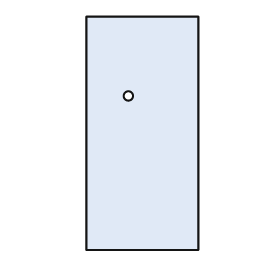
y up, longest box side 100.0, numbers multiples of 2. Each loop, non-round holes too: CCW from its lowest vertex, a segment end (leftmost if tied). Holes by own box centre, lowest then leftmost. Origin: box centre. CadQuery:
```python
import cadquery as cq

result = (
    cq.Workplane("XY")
    .moveTo(-24.0, -50.0)
    .lineTo(24.0, -50.0)
    .lineTo(24.0, 50.0)
    .lineTo(-24.0, 50.0)
    .close()
    .moveTo(-6.0, 16.0)
    .circle(2.0)
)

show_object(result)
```